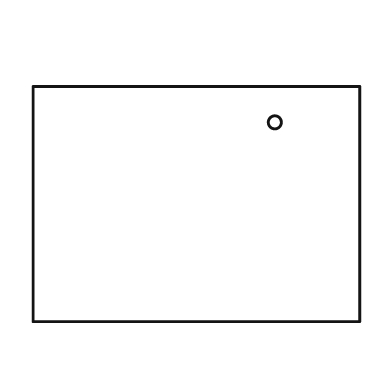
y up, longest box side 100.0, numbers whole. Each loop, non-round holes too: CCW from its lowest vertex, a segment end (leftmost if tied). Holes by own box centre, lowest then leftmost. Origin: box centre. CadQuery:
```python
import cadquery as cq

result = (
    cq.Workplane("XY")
    .moveTo(-50.0, -36.0)
    .lineTo(50.0, -36.0)
    .lineTo(50.0, 36.0)
    .lineTo(-50.0, 36.0)
    .close()
    .moveTo(24.0, 25.0)
    .circle(2.0)
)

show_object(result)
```